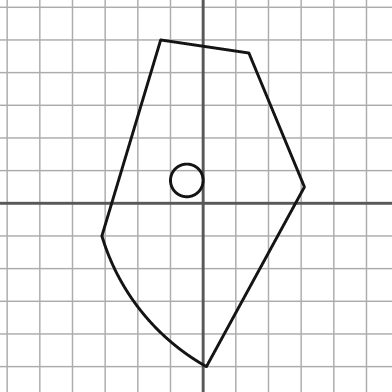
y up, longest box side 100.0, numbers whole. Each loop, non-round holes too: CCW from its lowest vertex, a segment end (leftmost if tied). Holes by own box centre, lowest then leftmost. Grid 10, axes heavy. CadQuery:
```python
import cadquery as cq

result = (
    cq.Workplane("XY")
    .moveTo(1.0, -50.0)
    .lineTo(31.0, 5.0)
    .lineTo(14.0, 46.0)
    .lineTo(-13.0, 50.0)
    .lineTo(-31.0, -10.0)
    .threePointArc((-19.0, -33.0), (1.0, -50.0))
    .close()
    .moveTo(-5.0, 7.0)
    .circle(5.0)
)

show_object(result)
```